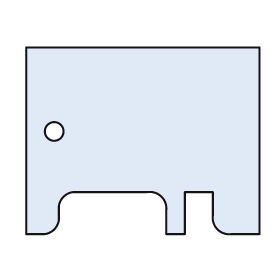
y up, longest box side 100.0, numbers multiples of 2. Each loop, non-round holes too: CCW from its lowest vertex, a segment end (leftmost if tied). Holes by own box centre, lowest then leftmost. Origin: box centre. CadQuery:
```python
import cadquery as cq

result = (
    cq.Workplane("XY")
    .moveTo(-50.0, -40.0)
    .lineTo(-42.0, -40.0)
    .threePointArc((-38.0, -38.0), (-36.0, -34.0))
    .lineTo(-36.0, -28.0)
    .threePointArc((-34.0, -24.0), (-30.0, -22.0))
    .lineTo(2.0, -22.0)
    .threePointArc((8.0, -24.0), (10.0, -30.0))
    .lineTo(10.0, -40.0)
    .lineTo(18.0, -40.0)
    .lineTo(18.0, -22.0)
    .lineTo(30.0, -22.0)
    .lineTo(30.0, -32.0)
    .threePointArc((32.0, -38.0), (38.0, -40.0))
    .lineTo(50.0, -40.0)
    .lineTo(50.0, 40.0)
    .lineTo(-50.0, 40.0)
    .close()
    .moveTo(-38.0, 4.0)
    .circle(4.0)
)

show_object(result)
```